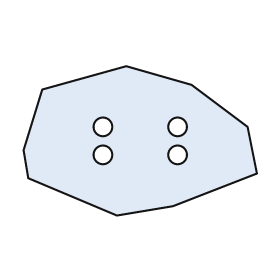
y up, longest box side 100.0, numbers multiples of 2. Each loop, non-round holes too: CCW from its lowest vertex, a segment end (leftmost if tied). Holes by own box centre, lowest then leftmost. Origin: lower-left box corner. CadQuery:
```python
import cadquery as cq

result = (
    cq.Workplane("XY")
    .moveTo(40.0, 0.0)
    .lineTo(64.0, 4.0)
    .lineTo(100.0, 18.0)
    .lineTo(96.0, 38.0)
    .lineTo(72.0, 56.0)
    .lineTo(44.0, 64.0)
    .lineTo(8.0, 54.0)
    .lineTo(0.0, 28.0)
    .lineTo(2.0, 16.0)
    .close()
    .moveTo(34.0, 26.0)
    .circle(4.0)
    .moveTo(66.0, 26.0)
    .circle(4.0)
    .moveTo(34.0, 38.0)
    .circle(4.0)
    .moveTo(66.0, 38.0)
    .circle(4.0)
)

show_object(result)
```